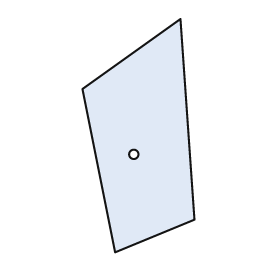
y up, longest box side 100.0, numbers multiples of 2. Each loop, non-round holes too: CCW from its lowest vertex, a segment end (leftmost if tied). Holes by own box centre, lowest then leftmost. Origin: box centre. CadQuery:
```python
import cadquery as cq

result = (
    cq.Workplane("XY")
    .moveTo(-10.0, -50.0)
    .lineTo(24.0, -36.0)
    .lineTo(18.0, 50.0)
    .lineTo(-24.0, 20.0)
    .close()
    .moveTo(-2.0, -8.0)
    .circle(2.0)
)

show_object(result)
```